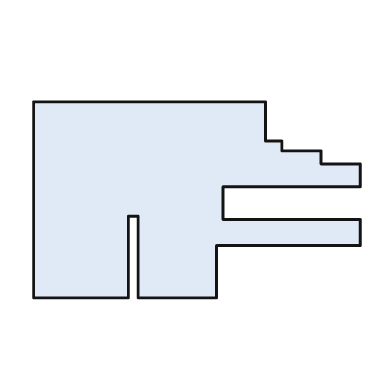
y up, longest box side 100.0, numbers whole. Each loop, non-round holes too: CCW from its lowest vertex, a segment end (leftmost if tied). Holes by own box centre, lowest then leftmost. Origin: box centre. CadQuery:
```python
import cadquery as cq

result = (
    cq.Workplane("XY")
    .moveTo(-50.0, -30.0)
    .lineTo(-21.0, -30.0)
    .lineTo(-21.0, -5.0)
    .lineTo(-18.0, -5.0)
    .lineTo(-18.0, -30.0)
    .lineTo(6.0, -30.0)
    .lineTo(6.0, -14.0)
    .lineTo(50.0, -14.0)
    .lineTo(50.0, -6.0)
    .lineTo(8.0, -6.0)
    .lineTo(8.0, 4.0)
    .lineTo(50.0, 4.0)
    .lineTo(50.0, 11.0)
    .lineTo(38.0, 11.0)
    .lineTo(38.0, 15.0)
    .lineTo(26.0, 15.0)
    .lineTo(26.0, 18.0)
    .lineTo(21.0, 18.0)
    .lineTo(21.0, 30.0)
    .lineTo(-50.0, 30.0)
    .close()
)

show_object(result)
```